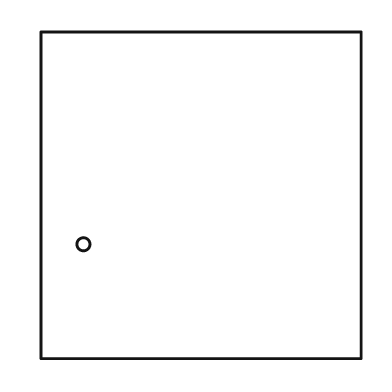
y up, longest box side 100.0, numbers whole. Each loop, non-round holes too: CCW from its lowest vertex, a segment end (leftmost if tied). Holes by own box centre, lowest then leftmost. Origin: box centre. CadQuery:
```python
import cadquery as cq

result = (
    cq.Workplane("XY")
    .moveTo(-49.0, -50.0)
    .lineTo(49.0, -50.0)
    .lineTo(49.0, 50.0)
    .lineTo(-49.0, 50.0)
    .close()
    .moveTo(-36.0, -15.0)
    .circle(2.0)
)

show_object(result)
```